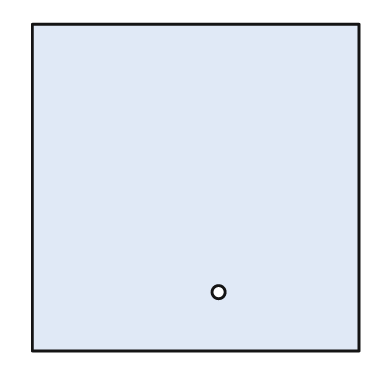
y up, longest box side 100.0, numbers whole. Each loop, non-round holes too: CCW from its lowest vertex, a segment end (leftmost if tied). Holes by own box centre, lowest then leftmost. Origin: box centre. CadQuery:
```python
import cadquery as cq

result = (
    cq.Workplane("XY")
    .moveTo(-50.0, -50.0)
    .lineTo(50.0, -50.0)
    .lineTo(50.0, 50.0)
    .lineTo(-50.0, 50.0)
    .close()
    .moveTo(7.0, -32.0)
    .circle(2.0)
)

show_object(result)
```